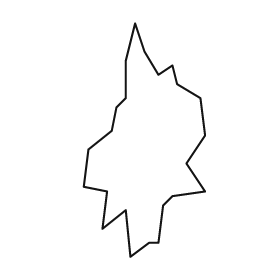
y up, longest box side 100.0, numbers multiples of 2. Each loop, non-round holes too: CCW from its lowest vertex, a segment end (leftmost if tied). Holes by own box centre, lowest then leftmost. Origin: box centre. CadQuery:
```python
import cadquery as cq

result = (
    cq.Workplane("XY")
    .moveTo(-6.0, -50.0)
    .lineTo(2.0, -44.0)
    .lineTo(6.0, -44.0)
    .lineTo(8.0, -28.0)
    .lineTo(12.0, -24.0)
    .lineTo(26.0, -22.0)
    .lineTo(18.0, -10.0)
    .lineTo(26.0, 2.0)
    .lineTo(24.0, 18.0)
    .lineTo(14.0, 24.0)
    .lineTo(12.0, 32.0)
    .lineTo(6.0, 28.0)
    .lineTo(0.0, 38.0)
    .lineTo(-4.0, 50.0)
    .lineTo(-8.0, 34.0)
    .lineTo(-8.0, 18.0)
    .lineTo(-12.0, 14.0)
    .lineTo(-14.0, 4.0)
    .lineTo(-24.0, -4.0)
    .lineTo(-26.0, -20.0)
    .lineTo(-16.0, -22.0)
    .lineTo(-18.0, -38.0)
    .lineTo(-8.0, -30.0)
    .close()
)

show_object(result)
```